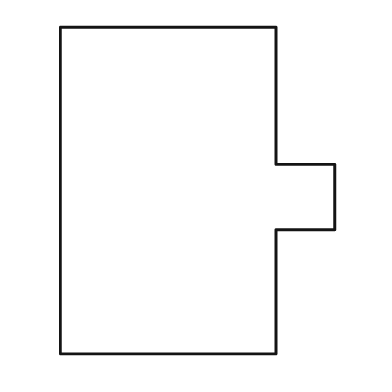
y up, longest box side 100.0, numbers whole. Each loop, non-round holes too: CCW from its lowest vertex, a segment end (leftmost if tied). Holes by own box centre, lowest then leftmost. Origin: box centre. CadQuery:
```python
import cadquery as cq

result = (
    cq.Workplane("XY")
    .moveTo(-42.0, -50.0)
    .lineTo(24.0, -50.0)
    .lineTo(24.0, -12.0)
    .lineTo(42.0, -12.0)
    .lineTo(42.0, 8.0)
    .lineTo(24.0, 8.0)
    .lineTo(24.0, 50.0)
    .lineTo(-42.0, 50.0)
    .close()
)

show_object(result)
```